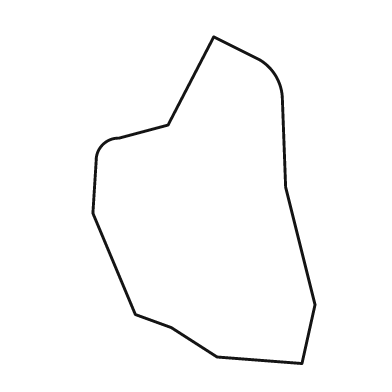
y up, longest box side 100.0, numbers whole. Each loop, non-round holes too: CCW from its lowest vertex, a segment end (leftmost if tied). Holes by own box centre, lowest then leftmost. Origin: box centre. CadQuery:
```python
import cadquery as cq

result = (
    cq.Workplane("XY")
    .moveTo(30.0, -50.0)
    .lineTo(34.0, -32.0)
    .lineTo(25.0, 4.0)
    .lineTo(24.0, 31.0)
    .threePointArc((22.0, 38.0), (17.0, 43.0))
    .lineTo(3.0, 50.0)
    .lineTo(-11.0, 23.0)
    .lineTo(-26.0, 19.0)
    .threePointArc((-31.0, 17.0), (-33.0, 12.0))
    .lineTo(-34.0, -4.0)
    .lineTo(-21.0, -35.0)
    .lineTo(-10.0, -39.0)
    .lineTo(4.0, -48.0)
    .close()
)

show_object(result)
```